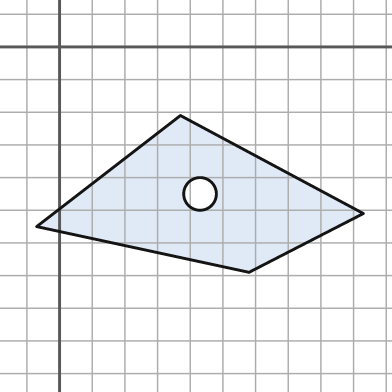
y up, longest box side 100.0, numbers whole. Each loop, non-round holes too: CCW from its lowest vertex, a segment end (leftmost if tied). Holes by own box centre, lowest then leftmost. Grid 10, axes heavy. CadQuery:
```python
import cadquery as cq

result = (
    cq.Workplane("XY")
    .moveTo(58.0, -69.0)
    .lineTo(93.0, -51.0)
    .lineTo(37.0, -21.0)
    .lineTo(-7.0, -55.0)
    .close()
    .moveTo(43.0, -45.0)
    .circle(5.0)
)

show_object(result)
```